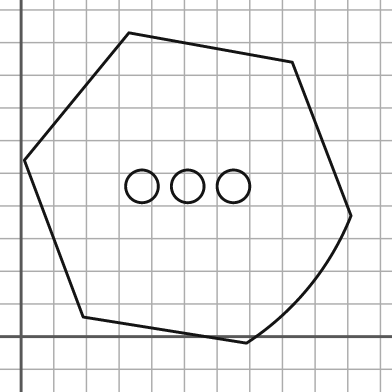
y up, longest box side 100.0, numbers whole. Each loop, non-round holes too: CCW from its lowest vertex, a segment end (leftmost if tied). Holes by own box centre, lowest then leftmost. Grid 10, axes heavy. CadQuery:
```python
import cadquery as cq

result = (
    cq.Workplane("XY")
    .moveTo(69.0, -2.0)
    .threePointArc((88.0, 15.0), (101.0, 37.0))
    .lineTo(83.0, 84.0)
    .lineTo(33.0, 93.0)
    .lineTo(1.0, 54.0)
    .lineTo(19.0, 6.0)
    .close()
    .moveTo(37.0, 46.0)
    .circle(5.0)
    .moveTo(51.0, 46.0)
    .circle(5.0)
    .moveTo(65.0, 46.0)
    .circle(5.0)
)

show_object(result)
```